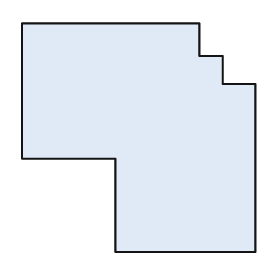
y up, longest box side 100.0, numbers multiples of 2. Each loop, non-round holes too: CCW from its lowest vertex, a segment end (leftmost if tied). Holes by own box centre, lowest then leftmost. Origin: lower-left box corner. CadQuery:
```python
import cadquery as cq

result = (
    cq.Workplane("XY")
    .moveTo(40.0, 0.0)
    .lineTo(100.0, 0.0)
    .lineTo(100.0, 72.0)
    .lineTo(86.0, 72.0)
    .lineTo(86.0, 84.0)
    .lineTo(76.0, 84.0)
    .lineTo(76.0, 98.0)
    .lineTo(0.0, 98.0)
    .lineTo(0.0, 40.0)
    .lineTo(40.0, 40.0)
    .close()
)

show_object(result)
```